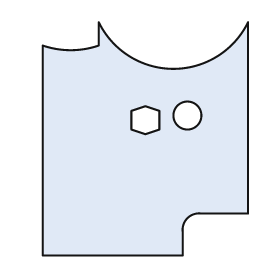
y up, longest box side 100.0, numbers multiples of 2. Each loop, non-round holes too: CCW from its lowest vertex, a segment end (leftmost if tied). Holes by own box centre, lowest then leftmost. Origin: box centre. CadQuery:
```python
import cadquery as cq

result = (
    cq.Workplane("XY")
    .moveTo(-44.0, -50.0)
    .lineTo(16.0, -50.0)
    .lineTo(16.0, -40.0)
    .threePointArc((18.0, -34.0), (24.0, -32.0))
    .lineTo(44.0, -32.0)
    .lineTo(44.0, 50.0)
    .threePointArc((12.0, 30.0), (-20.0, 50.0))
    .lineTo(-20.0, 40.0)
    .threePointArc((-32.0, 38.0), (-44.0, 40.0))
    .close()
    .moveTo(0.0, 2.0)
    .lineTo(6.0, 4.0)
    .lineTo(6.0, 12.0)
    .lineTo(0.0, 14.0)
    .lineTo(-6.0, 12.0)
    .lineTo(-6.0, 4.0)
    .close()
    .moveTo(18.0, 10.0)
    .circle(6.0)
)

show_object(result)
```